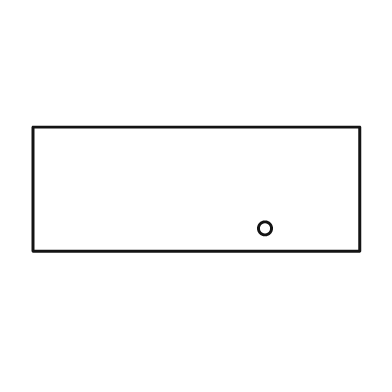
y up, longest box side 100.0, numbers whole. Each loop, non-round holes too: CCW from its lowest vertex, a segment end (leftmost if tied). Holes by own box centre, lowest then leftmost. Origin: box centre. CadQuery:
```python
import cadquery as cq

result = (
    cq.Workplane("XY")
    .moveTo(-50.0, -19.0)
    .lineTo(50.0, -19.0)
    .lineTo(50.0, 19.0)
    .lineTo(-50.0, 19.0)
    .close()
    .moveTo(21.0, -12.0)
    .circle(2.0)
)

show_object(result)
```